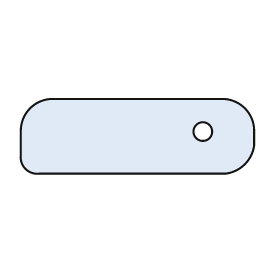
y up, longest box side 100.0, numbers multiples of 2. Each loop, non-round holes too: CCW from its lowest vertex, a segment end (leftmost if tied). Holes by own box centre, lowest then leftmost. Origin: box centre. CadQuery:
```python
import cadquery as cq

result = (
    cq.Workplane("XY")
    .moveTo(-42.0, -16.0)
    .lineTo(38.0, -16.0)
    .threePointArc((46.0, -12.0), (50.0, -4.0))
    .lineTo(50.0, 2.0)
    .threePointArc((46.0, 12.0), (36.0, 16.0))
    .lineTo(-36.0, 16.0)
    .threePointArc((-46.0, 12.0), (-50.0, 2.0))
    .lineTo(-50.0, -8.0)
    .threePointArc((-48.0, -14.0), (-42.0, -16.0))
    .close()
    .moveTo(28.0, 2.0)
    .circle(4.0)
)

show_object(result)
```